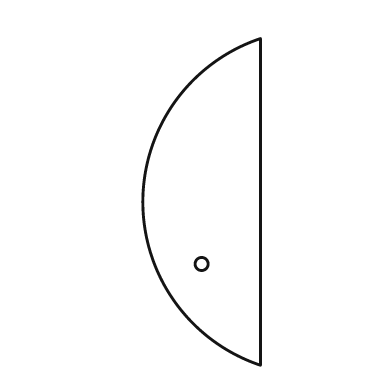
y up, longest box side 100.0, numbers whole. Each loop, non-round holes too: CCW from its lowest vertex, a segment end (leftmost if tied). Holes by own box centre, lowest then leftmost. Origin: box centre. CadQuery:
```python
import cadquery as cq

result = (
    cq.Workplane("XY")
    .moveTo(18.0, -50.0)
    .lineTo(18.0, 50.0)
    .threePointArc((-18.0, 0.0), (18.0, -50.0))
    .close()
    .moveTo(0.0, -19.0)
    .circle(2.0)
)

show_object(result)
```